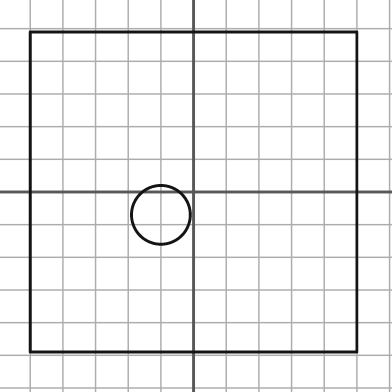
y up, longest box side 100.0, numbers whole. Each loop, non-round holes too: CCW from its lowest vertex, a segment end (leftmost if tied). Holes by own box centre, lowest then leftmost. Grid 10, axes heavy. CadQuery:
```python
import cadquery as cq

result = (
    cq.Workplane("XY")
    .moveTo(-50.0, -49.0)
    .lineTo(50.0, -49.0)
    .lineTo(50.0, 49.0)
    .lineTo(-50.0, 49.0)
    .close()
    .moveTo(-10.0, -7.0)
    .circle(9.0)
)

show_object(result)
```